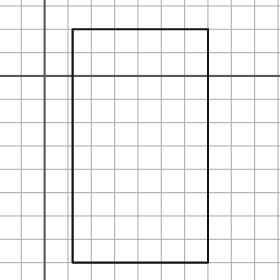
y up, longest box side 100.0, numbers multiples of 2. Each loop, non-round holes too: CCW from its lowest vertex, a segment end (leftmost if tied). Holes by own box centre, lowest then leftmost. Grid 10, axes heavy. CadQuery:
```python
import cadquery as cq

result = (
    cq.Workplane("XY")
    .moveTo(12.0, -80.0)
    .lineTo(70.0, -80.0)
    .lineTo(70.0, 20.0)
    .lineTo(12.0, 20.0)
    .close()
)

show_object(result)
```